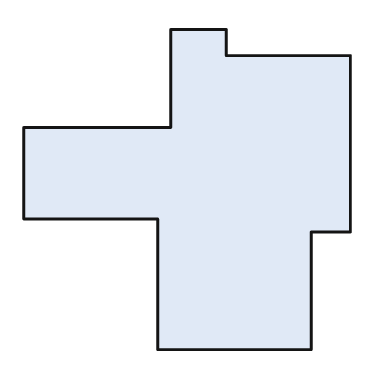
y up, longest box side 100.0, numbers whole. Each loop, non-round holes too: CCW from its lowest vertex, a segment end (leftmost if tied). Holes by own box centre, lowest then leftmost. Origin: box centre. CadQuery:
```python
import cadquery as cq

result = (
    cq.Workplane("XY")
    .moveTo(-9.0, -49.0)
    .lineTo(38.0, -49.0)
    .lineTo(38.0, -13.0)
    .lineTo(50.0, -13.0)
    .lineTo(50.0, 41.0)
    .lineTo(12.0, 41.0)
    .lineTo(12.0, 49.0)
    .lineTo(-5.0, 49.0)
    .lineTo(-5.0, 19.0)
    .lineTo(-50.0, 19.0)
    .lineTo(-50.0, -9.0)
    .lineTo(-9.0, -9.0)
    .close()
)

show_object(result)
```